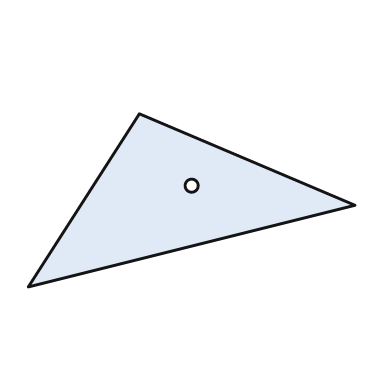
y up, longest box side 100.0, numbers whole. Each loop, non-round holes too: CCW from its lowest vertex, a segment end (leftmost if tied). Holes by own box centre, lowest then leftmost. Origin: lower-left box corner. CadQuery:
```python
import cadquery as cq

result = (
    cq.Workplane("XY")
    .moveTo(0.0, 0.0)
    .lineTo(100.0, 25.0)
    .lineTo(34.0, 53.0)
    .close()
    .moveTo(50.0, 31.0)
    .circle(2.0)
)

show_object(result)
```